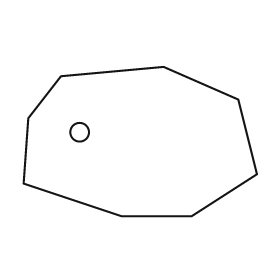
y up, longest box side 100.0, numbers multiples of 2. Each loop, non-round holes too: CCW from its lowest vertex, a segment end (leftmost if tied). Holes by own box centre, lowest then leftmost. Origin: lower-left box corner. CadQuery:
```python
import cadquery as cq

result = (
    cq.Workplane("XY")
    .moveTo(42.0, 0.0)
    .lineTo(72.0, 0.0)
    .lineTo(100.0, 18.0)
    .lineTo(92.0, 50.0)
    .lineTo(60.0, 64.0)
    .lineTo(16.0, 60.0)
    .lineTo(2.0, 42.0)
    .lineTo(0.0, 14.0)
    .close()
    .moveTo(24.0, 36.0)
    .circle(4.0)
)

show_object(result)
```